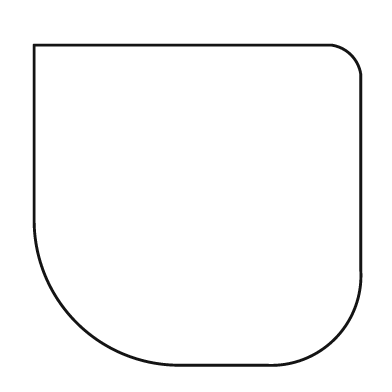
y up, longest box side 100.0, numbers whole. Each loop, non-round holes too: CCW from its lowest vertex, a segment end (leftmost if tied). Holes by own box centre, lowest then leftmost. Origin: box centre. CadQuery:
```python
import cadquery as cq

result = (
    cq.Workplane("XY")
    .moveTo(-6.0, -49.0)
    .lineTo(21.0, -49.0)
    .threePointArc((42.0, -41.0), (50.0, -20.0))
    .lineTo(50.0, 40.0)
    .threePointArc((47.0, 46.0), (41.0, 49.0))
    .lineTo(-50.0, 49.0)
    .lineTo(-50.0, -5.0)
    .threePointArc((-37.0, -36.0), (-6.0, -49.0))
    .close()
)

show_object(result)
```